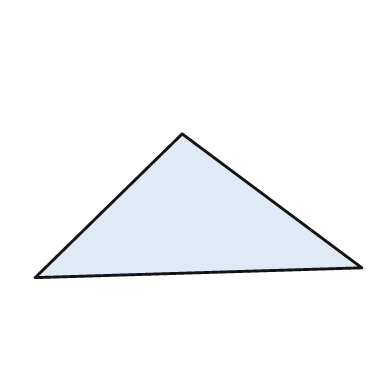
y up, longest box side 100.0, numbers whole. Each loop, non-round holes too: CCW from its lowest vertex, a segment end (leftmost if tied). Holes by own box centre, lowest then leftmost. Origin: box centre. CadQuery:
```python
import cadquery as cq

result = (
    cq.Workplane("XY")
    .moveTo(-50.0, -22.0)
    .lineTo(50.0, -19.0)
    .lineTo(-5.0, 22.0)
    .close()
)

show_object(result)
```